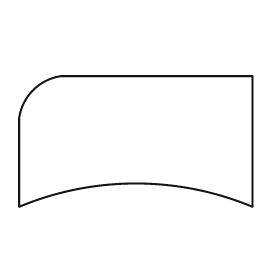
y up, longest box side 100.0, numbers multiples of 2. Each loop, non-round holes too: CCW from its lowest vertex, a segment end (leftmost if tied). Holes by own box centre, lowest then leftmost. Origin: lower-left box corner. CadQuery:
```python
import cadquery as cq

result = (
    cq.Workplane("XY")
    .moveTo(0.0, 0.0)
    .threePointArc((50.0, 10.0), (100.0, 0.0))
    .lineTo(100.0, 56.0)
    .lineTo(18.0, 56.0)
    .threePointArc((6.0, 50.0), (0.0, 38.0))
    .close()
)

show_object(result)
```